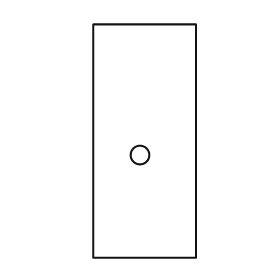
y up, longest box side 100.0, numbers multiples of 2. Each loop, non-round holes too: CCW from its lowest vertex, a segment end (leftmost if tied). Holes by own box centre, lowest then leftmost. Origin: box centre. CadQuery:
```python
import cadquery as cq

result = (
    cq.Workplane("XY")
    .moveTo(-22.0, -50.0)
    .lineTo(22.0, -50.0)
    .lineTo(22.0, 50.0)
    .lineTo(-22.0, 50.0)
    .close()
    .moveTo(-2.0, -6.0)
    .circle(4.0)
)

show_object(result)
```